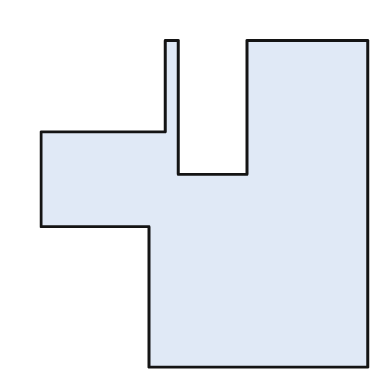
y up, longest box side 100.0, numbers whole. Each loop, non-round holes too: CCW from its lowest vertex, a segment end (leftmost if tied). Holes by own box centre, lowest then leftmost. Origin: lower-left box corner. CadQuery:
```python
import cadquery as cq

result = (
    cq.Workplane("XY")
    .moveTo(33.0, 0.0)
    .lineTo(100.0, 0.0)
    .lineTo(100.0, 100.0)
    .lineTo(63.0, 100.0)
    .lineTo(63.0, 59.0)
    .lineTo(42.0, 59.0)
    .lineTo(42.0, 100.0)
    .lineTo(38.0, 100.0)
    .lineTo(38.0, 72.0)
    .lineTo(0.0, 72.0)
    .lineTo(0.0, 43.0)
    .lineTo(33.0, 43.0)
    .close()
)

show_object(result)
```